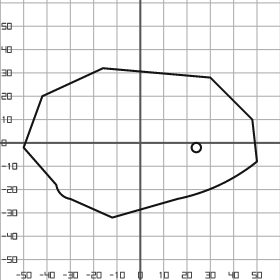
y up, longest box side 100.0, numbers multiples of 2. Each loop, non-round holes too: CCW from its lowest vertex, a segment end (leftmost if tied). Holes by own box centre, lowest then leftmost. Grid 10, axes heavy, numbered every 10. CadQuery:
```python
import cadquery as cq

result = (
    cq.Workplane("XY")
    .moveTo(-12.0, -32.0)
    .lineTo(16.0, -24.0)
    .threePointArc((34.0, -18.0), (50.0, -8.0))
    .lineTo(48.0, 10.0)
    .lineTo(30.0, 28.0)
    .lineTo(-16.0, 32.0)
    .lineTo(-42.0, 20.0)
    .lineTo(-50.0, -2.0)
    .lineTo(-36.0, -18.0)
    .threePointArc((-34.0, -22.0), (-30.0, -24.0))
    .close()
    .moveTo(24.0, -2.0)
    .circle(2.0)
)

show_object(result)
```